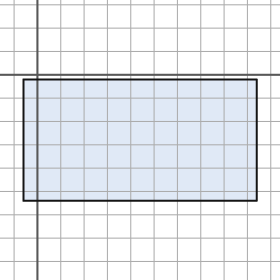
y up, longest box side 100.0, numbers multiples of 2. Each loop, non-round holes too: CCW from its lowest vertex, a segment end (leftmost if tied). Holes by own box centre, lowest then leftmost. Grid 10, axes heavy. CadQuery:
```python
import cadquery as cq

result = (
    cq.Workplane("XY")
    .moveTo(-6.0, -54.0)
    .lineTo(94.0, -54.0)
    .lineTo(94.0, -2.0)
    .lineTo(-6.0, -2.0)
    .close()
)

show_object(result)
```